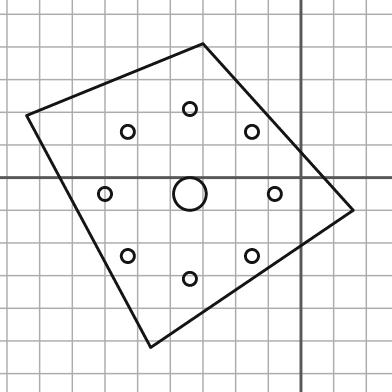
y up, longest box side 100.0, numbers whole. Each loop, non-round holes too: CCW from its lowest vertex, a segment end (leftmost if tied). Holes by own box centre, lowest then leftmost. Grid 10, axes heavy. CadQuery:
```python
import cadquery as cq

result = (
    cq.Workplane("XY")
    .moveTo(-46.0, -52.0)
    .lineTo(16.0, -10.0)
    .lineTo(-30.0, 41.0)
    .lineTo(-84.0, 19.0)
    .close()
    .moveTo(-34.0, -31.0)
    .circle(2.0)
    .moveTo(-53.0, -24.0)
    .circle(2.0)
    .moveTo(-15.0, -24.0)
    .circle(2.0)
    .moveTo(-60.0, -5.0)
    .circle(2.0)
    .moveTo(-34.0, -5.0)
    .circle(5.0)
    .moveTo(-8.0, -5.0)
    .circle(2.0)
    .moveTo(-53.0, 14.0)
    .circle(2.0)
    .moveTo(-15.0, 14.0)
    .circle(2.0)
    .moveTo(-34.0, 21.0)
    .circle(2.0)
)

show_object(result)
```